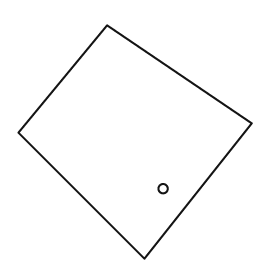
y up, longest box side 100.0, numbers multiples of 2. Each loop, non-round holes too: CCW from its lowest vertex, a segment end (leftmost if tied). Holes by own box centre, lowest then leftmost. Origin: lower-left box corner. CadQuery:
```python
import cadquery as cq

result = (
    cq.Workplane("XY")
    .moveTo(54.0, 0.0)
    .lineTo(100.0, 58.0)
    .lineTo(38.0, 100.0)
    .lineTo(0.0, 54.0)
    .close()
    .moveTo(62.0, 30.0)
    .circle(2.0)
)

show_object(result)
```